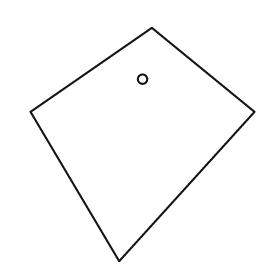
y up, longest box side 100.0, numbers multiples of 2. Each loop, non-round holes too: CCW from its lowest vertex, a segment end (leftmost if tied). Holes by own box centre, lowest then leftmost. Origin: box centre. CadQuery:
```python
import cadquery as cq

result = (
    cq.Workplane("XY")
    .moveTo(-10.0, -50.0)
    .lineTo(48.0, 14.0)
    .lineTo(4.0, 50.0)
    .lineTo(-48.0, 14.0)
    .close()
    .moveTo(0.0, 28.0)
    .circle(2.0)
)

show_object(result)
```